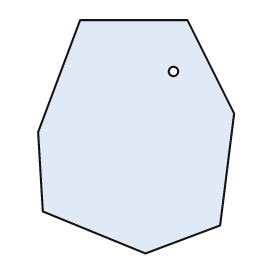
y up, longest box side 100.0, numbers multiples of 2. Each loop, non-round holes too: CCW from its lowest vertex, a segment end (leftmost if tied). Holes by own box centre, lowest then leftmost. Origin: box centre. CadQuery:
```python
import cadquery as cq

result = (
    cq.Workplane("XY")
    .moveTo(4.0, -50.0)
    .lineTo(36.0, -38.0)
    .lineTo(42.0, 10.0)
    .lineTo(22.0, 50.0)
    .lineTo(-24.0, 50.0)
    .lineTo(-42.0, 2.0)
    .lineTo(-40.0, -32.0)
    .close()
    .moveTo(16.0, 28.0)
    .circle(2.0)
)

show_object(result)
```